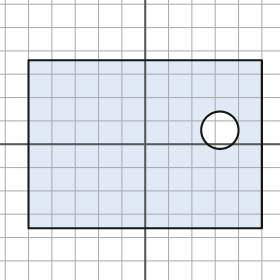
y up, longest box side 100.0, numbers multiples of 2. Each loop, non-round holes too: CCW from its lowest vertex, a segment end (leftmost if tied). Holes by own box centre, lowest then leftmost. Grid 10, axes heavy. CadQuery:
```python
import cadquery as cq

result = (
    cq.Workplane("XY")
    .moveTo(-50.0, -36.0)
    .lineTo(50.0, -36.0)
    .lineTo(50.0, 36.0)
    .lineTo(-50.0, 36.0)
    .close()
    .moveTo(32.0, 6.0)
    .circle(8.0)
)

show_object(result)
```